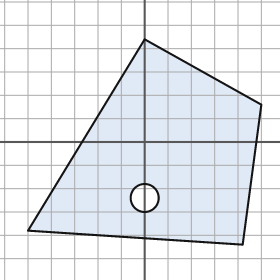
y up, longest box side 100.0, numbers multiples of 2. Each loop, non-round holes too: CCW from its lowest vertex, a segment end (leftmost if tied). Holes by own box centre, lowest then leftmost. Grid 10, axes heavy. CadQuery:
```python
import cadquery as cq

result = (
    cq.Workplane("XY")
    .moveTo(42.0, -44.0)
    .lineTo(50.0, 16.0)
    .lineTo(0.0, 44.0)
    .lineTo(-50.0, -38.0)
    .close()
    .moveTo(0.0, -24.0)
    .circle(6.0)
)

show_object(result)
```